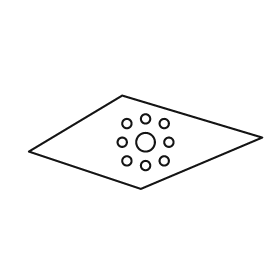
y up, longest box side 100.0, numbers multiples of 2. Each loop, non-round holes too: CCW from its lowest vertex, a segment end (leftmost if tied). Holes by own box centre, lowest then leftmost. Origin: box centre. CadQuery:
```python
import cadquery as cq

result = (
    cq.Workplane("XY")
    .moveTo(-2.0, -20.0)
    .lineTo(50.0, 2.0)
    .lineTo(-10.0, 20.0)
    .lineTo(-50.0, -4.0)
    .close()
    .moveTo(0.0, -10.0)
    .circle(2.0)
    .moveTo(-8.0, -8.0)
    .circle(2.0)
    .moveTo(8.0, -8.0)
    .circle(2.0)
    .moveTo(-10.0, 0.0)
    .circle(2.0)
    .moveTo(0.0, 0.0)
    .circle(4.0)
    .moveTo(10.0, 0.0)
    .circle(2.0)
    .moveTo(-8.0, 8.0)
    .circle(2.0)
    .moveTo(8.0, 8.0)
    .circle(2.0)
    .moveTo(0.0, 10.0)
    .circle(2.0)
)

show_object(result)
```